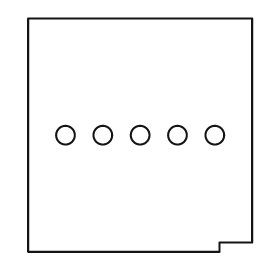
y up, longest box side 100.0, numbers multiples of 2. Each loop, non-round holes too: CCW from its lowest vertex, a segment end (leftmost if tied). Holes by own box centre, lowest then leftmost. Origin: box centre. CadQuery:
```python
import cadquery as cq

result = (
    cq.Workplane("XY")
    .moveTo(-48.0, -50.0)
    .lineTo(34.0, -50.0)
    .lineTo(34.0, -46.0)
    .lineTo(48.0, -46.0)
    .lineTo(48.0, 50.0)
    .lineTo(-48.0, 50.0)
    .close()
    .moveTo(-32.0, 0.0)
    .circle(4.0)
    .moveTo(-16.0, 0.0)
    .circle(4.0)
    .moveTo(0.0, 0.0)
    .circle(4.0)
    .moveTo(16.0, 0.0)
    .circle(4.0)
    .moveTo(32.0, 0.0)
    .circle(4.0)
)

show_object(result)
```